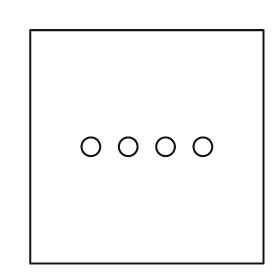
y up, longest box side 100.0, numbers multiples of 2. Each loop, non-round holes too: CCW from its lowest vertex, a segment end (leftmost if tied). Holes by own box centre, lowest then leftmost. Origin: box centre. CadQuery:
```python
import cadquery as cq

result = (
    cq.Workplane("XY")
    .moveTo(-50.0, -50.0)
    .lineTo(50.0, -50.0)
    .lineTo(50.0, 50.0)
    .lineTo(-50.0, 50.0)
    .close()
    .moveTo(-24.0, 0.0)
    .circle(4.0)
    .moveTo(-8.0, 0.0)
    .circle(4.0)
    .moveTo(8.0, 0.0)
    .circle(4.0)
    .moveTo(24.0, 0.0)
    .circle(4.0)
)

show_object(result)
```